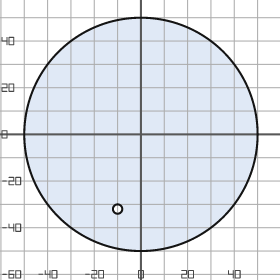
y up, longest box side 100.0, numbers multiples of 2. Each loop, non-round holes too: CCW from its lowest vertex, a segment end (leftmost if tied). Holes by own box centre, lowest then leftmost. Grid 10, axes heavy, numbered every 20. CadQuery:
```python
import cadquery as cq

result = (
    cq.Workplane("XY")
    .moveTo(0.0, 0.0)
    .circle(50.0)
    .moveTo(-10.0, -32.0)
    .circle(2.0)
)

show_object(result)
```